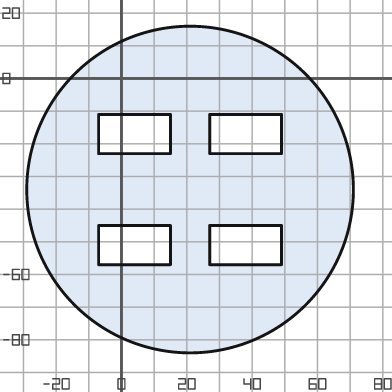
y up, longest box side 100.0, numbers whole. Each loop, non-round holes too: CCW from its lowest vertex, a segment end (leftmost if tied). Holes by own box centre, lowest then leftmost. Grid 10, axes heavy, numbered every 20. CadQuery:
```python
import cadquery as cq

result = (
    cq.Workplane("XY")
    .moveTo(21.0, -34.0)
    .circle(50.0)
    .moveTo(-7.0, -57.0)
    .lineTo(15.0, -57.0)
    .lineTo(15.0, -45.0)
    .lineTo(-7.0, -45.0)
    .close()
    .moveTo(27.0, -57.0)
    .lineTo(49.0, -57.0)
    .lineTo(49.0, -45.0)
    .lineTo(27.0, -45.0)
    .close()
    .moveTo(-7.0, -23.0)
    .lineTo(15.0, -23.0)
    .lineTo(15.0, -11.0)
    .lineTo(-7.0, -11.0)
    .close()
    .moveTo(27.0, -23.0)
    .lineTo(49.0, -23.0)
    .lineTo(49.0, -11.0)
    .lineTo(27.0, -11.0)
    .close()
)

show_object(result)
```